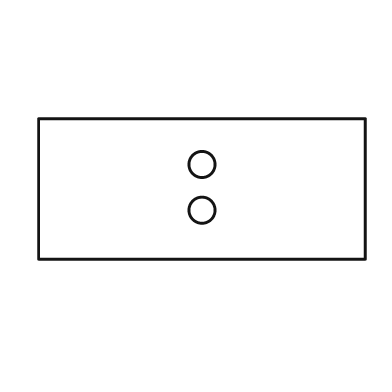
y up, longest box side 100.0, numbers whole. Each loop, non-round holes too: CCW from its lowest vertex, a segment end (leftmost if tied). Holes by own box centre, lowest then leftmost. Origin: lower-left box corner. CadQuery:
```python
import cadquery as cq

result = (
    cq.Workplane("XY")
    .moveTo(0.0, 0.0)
    .lineTo(100.0, 0.0)
    .lineTo(100.0, 43.0)
    .lineTo(0.0, 43.0)
    .close()
    .moveTo(50.0, 15.0)
    .circle(4.0)
    .moveTo(50.0, 29.0)
    .circle(4.0)
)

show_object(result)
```